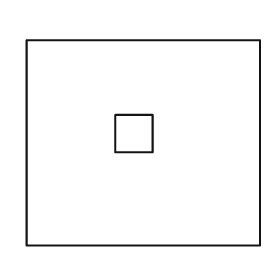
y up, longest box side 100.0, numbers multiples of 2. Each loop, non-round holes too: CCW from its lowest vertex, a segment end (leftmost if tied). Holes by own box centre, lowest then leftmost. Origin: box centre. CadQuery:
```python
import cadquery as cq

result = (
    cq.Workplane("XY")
    .moveTo(-50.0, -44.0)
    .lineTo(50.0, -44.0)
    .lineTo(50.0, 44.0)
    .lineTo(-50.0, 44.0)
    .close()
    .moveTo(-12.0, -4.0)
    .lineTo(4.0, -4.0)
    .lineTo(4.0, 12.0)
    .lineTo(-12.0, 12.0)
    .close()
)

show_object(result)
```